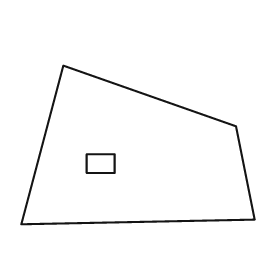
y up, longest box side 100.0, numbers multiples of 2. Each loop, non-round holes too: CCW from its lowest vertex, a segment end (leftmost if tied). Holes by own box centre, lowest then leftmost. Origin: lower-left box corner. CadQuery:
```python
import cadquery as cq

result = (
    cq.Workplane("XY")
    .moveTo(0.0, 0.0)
    .lineTo(100.0, 2.0)
    .lineTo(92.0, 42.0)
    .lineTo(18.0, 68.0)
    .close()
    .moveTo(28.0, 22.0)
    .lineTo(40.0, 22.0)
    .lineTo(40.0, 30.0)
    .lineTo(28.0, 30.0)
    .close()
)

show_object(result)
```